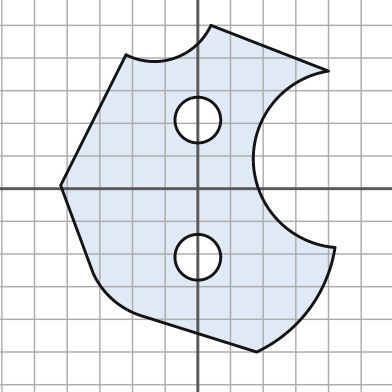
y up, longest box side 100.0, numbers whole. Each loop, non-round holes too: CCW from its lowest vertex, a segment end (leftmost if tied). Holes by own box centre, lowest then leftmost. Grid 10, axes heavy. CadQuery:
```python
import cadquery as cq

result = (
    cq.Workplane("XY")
    .moveTo(18.0, -50.0)
    .threePointArc((34.0, -37.0), (42.0, -18.0))
    .threePointArc((17.0, 8.0), (40.0, 36.0))
    .lineTo(4.0, 50.0)
    .threePointArc((-7.0, 40.0), (-22.0, 41.0))
    .lineTo(-42.0, 1.0)
    .lineTo(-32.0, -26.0)
    .threePointArc((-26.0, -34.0), (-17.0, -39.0))
    .close()
    .moveTo(0.0, -21.0)
    .circle(7.0)
    .moveTo(0.0, 21.0)
    .circle(7.0)
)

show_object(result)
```